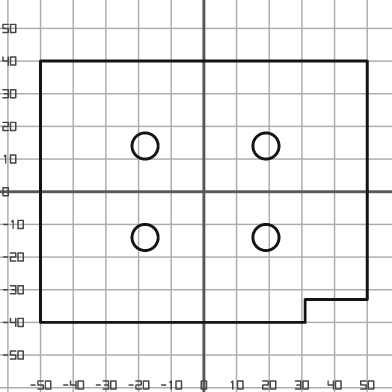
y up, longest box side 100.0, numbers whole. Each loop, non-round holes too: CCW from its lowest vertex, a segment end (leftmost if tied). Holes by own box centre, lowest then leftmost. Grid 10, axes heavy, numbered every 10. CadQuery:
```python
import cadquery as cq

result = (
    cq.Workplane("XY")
    .moveTo(-50.0, -40.0)
    .lineTo(31.0, -40.0)
    .lineTo(31.0, -33.0)
    .lineTo(50.0, -33.0)
    .lineTo(50.0, 40.0)
    .lineTo(-50.0, 40.0)
    .close()
    .moveTo(-18.0, -14.0)
    .circle(4.0)
    .moveTo(19.0, -14.0)
    .circle(4.0)
    .moveTo(-18.0, 14.0)
    .circle(4.0)
    .moveTo(19.0, 14.0)
    .circle(4.0)
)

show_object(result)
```